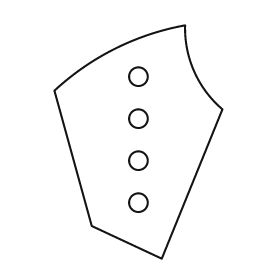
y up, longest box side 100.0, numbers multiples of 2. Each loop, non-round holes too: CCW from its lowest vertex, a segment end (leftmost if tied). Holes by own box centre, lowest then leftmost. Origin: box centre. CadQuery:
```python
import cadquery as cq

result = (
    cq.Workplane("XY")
    .moveTo(10.0, -50.0)
    .lineTo(36.0, 14.0)
    .threePointArc((24.0, 30.0), (20.0, 50.0))
    .threePointArc((-10.0, 40.0), (-36.0, 22.0))
    .lineTo(-20.0, -36.0)
    .close()
    .moveTo(0.0, -26.0)
    .circle(4.0)
    .moveTo(0.0, -8.0)
    .circle(4.0)
    .moveTo(0.0, 10.0)
    .circle(4.0)
    .moveTo(0.0, 28.0)
    .circle(4.0)
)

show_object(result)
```